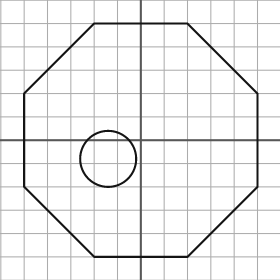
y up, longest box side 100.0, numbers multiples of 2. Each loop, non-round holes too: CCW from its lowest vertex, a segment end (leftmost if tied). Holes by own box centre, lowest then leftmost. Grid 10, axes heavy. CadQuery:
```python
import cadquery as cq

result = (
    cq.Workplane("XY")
    .moveTo(-20.0, -50.0)
    .lineTo(20.0, -50.0)
    .lineTo(50.0, -20.0)
    .lineTo(50.0, 20.0)
    .lineTo(20.0, 50.0)
    .lineTo(-20.0, 50.0)
    .lineTo(-50.0, 20.0)
    .lineTo(-50.0, -20.0)
    .close()
    .moveTo(-14.0, -8.0)
    .circle(12.0)
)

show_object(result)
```